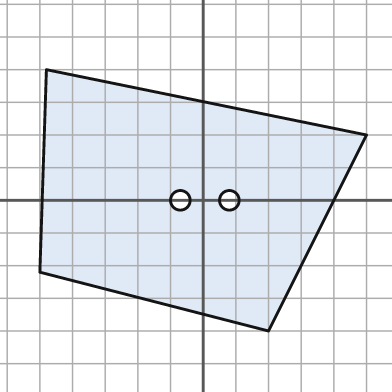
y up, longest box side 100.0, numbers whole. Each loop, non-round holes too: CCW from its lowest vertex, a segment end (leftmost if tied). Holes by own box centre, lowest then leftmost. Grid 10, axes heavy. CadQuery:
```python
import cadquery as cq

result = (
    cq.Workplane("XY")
    .moveTo(20.0, -40.0)
    .lineTo(50.0, 20.0)
    .lineTo(-48.0, 40.0)
    .lineTo(-50.0, -22.0)
    .close()
    .moveTo(-7.0, 0.0)
    .circle(3.0)
    .moveTo(8.0, 0.0)
    .circle(3.0)
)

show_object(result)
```